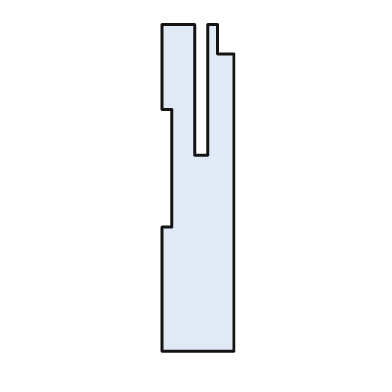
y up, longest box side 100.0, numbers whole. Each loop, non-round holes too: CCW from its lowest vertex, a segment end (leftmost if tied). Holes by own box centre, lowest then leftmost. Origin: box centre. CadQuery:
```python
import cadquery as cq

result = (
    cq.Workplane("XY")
    .moveTo(-11.0, -50.0)
    .lineTo(11.0, -50.0)
    .lineTo(11.0, 41.0)
    .lineTo(6.0, 41.0)
    .lineTo(6.0, 50.0)
    .lineTo(3.0, 50.0)
    .lineTo(3.0, 10.0)
    .lineTo(-1.0, 10.0)
    .lineTo(-1.0, 50.0)
    .lineTo(-11.0, 50.0)
    .lineTo(-11.0, 24.0)
    .lineTo(-8.0, 24.0)
    .lineTo(-8.0, -12.0)
    .lineTo(-11.0, -12.0)
    .close()
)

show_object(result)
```